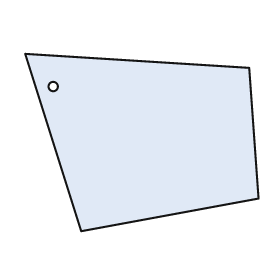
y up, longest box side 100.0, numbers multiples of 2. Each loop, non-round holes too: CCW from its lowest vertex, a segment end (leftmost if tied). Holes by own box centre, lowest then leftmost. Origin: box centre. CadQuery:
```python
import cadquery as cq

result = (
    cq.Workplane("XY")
    .moveTo(-26.0, -38.0)
    .lineTo(50.0, -24.0)
    .lineTo(46.0, 32.0)
    .lineTo(-50.0, 38.0)
    .close()
    .moveTo(-38.0, 24.0)
    .circle(2.0)
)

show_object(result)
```